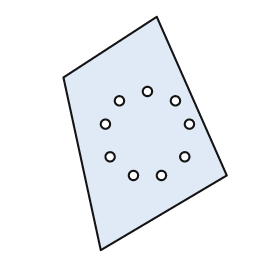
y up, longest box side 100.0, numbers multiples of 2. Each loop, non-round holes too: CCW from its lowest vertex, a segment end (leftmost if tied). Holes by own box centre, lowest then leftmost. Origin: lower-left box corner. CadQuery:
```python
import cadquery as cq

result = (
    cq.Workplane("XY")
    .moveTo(16.0, 0.0)
    .lineTo(70.0, 32.0)
    .lineTo(40.0, 100.0)
    .lineTo(0.0, 74.0)
    .close()
    .moveTo(30.0, 32.0)
    .circle(2.0)
    .moveTo(42.0, 32.0)
    .circle(2.0)
    .moveTo(20.0, 40.0)
    .circle(2.0)
    .moveTo(52.0, 40.0)
    .circle(2.0)
    .moveTo(18.0, 54.0)
    .circle(2.0)
    .moveTo(54.0, 54.0)
    .circle(2.0)
    .moveTo(24.0, 64.0)
    .circle(2.0)
    .moveTo(48.0, 64.0)
    .circle(2.0)
    .moveTo(36.0, 68.0)
    .circle(2.0)
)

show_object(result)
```